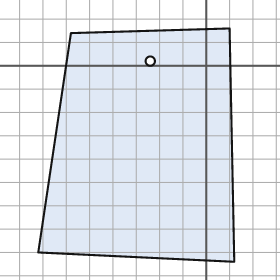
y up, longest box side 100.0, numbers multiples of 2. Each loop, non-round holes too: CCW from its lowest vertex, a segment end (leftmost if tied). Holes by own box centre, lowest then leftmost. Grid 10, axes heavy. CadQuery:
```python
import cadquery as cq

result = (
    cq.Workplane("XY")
    .moveTo(12.0, -84.0)
    .lineTo(10.0, 16.0)
    .lineTo(-58.0, 14.0)
    .lineTo(-72.0, -80.0)
    .close()
    .moveTo(-24.0, 2.0)
    .circle(2.0)
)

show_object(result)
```